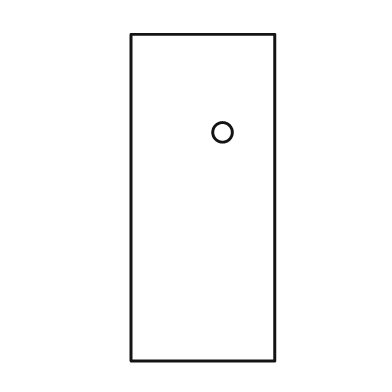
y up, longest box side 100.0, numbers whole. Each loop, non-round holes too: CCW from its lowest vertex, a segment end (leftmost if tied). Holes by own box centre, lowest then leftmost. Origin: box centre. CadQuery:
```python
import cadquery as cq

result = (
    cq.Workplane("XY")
    .moveTo(-22.0, -50.0)
    .lineTo(22.0, -50.0)
    .lineTo(22.0, 50.0)
    .lineTo(-22.0, 50.0)
    .close()
    .moveTo(6.0, 20.0)
    .circle(3.0)
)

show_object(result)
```